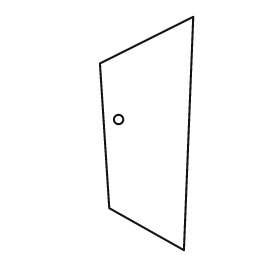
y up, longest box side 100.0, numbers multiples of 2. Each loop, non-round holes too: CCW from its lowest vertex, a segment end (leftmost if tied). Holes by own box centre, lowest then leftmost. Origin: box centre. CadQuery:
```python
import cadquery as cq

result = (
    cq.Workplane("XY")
    .moveTo(16.0, -50.0)
    .lineTo(20.0, 50.0)
    .lineTo(-20.0, 30.0)
    .lineTo(-16.0, -32.0)
    .close()
    .moveTo(-12.0, 6.0)
    .circle(2.0)
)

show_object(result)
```